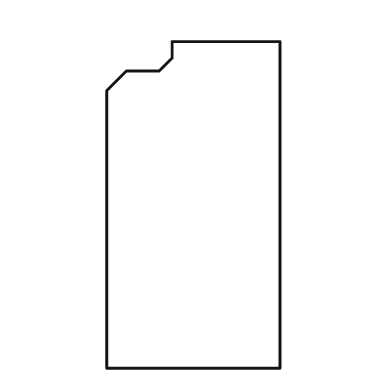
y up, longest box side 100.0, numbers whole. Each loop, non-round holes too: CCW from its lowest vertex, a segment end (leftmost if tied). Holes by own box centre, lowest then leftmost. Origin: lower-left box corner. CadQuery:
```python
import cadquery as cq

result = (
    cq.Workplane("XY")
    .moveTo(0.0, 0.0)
    .lineTo(53.0, 0.0)
    .lineTo(53.0, 100.0)
    .lineTo(20.0, 100.0)
    .lineTo(20.0, 95.0)
    .lineTo(16.0, 91.0)
    .lineTo(6.0, 91.0)
    .lineTo(0.0, 85.0)
    .close()
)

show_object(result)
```